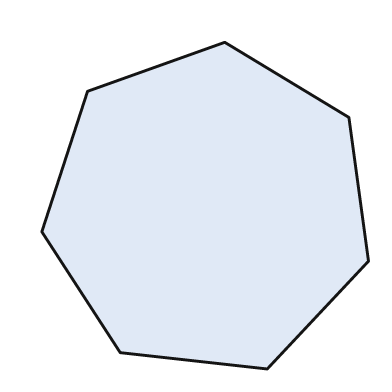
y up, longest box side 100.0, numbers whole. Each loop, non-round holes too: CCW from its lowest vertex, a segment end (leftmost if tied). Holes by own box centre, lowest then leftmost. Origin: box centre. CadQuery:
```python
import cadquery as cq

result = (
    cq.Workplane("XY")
    .moveTo(19.0, -50.0)
    .lineTo(50.0, -17.0)
    .lineTo(44.0, 27.0)
    .lineTo(6.0, 50.0)
    .lineTo(-36.0, 35.0)
    .lineTo(-50.0, -8.0)
    .lineTo(-26.0, -45.0)
    .close()
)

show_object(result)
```